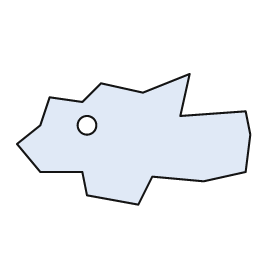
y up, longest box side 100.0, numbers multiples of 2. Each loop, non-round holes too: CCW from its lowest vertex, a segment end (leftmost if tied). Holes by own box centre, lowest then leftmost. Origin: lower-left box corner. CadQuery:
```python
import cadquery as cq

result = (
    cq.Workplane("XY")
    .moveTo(52.0, 0.0)
    .lineTo(58.0, 12.0)
    .lineTo(80.0, 10.0)
    .lineTo(98.0, 14.0)
    .lineTo(100.0, 30.0)
    .lineTo(98.0, 40.0)
    .lineTo(70.0, 38.0)
    .lineTo(74.0, 56.0)
    .lineTo(54.0, 48.0)
    .lineTo(36.0, 52.0)
    .lineTo(28.0, 44.0)
    .lineTo(14.0, 46.0)
    .lineTo(10.0, 34.0)
    .lineTo(0.0, 26.0)
    .lineTo(10.0, 14.0)
    .lineTo(28.0, 14.0)
    .lineTo(30.0, 4.0)
    .close()
    .moveTo(30.0, 34.0)
    .circle(4.0)
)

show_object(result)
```